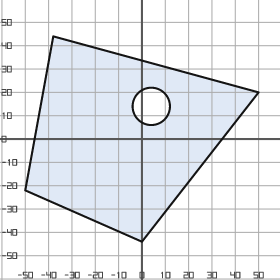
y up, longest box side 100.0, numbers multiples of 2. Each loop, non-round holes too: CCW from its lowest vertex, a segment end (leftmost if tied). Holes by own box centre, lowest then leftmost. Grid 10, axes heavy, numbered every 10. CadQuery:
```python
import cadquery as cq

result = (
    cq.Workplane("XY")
    .moveTo(0.0, -44.0)
    .lineTo(50.0, 20.0)
    .lineTo(-38.0, 44.0)
    .lineTo(-50.0, -22.0)
    .close()
    .moveTo(4.0, 14.0)
    .circle(8.0)
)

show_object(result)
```